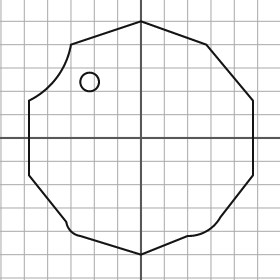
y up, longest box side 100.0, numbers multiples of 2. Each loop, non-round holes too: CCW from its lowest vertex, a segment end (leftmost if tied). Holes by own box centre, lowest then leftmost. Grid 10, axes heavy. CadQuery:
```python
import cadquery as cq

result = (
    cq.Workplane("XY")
    .moveTo(0.0, -50.0)
    .lineTo(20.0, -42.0)
    .threePointArc((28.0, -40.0), (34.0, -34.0))
    .lineTo(48.0, -16.0)
    .lineTo(48.0, 16.0)
    .lineTo(28.0, 40.0)
    .lineTo(0.0, 50.0)
    .lineTo(-30.0, 40.0)
    .threePointArc((-36.0, 26.0), (-48.0, 16.0))
    .lineTo(-48.0, -16.0)
    .lineTo(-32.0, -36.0)
    .threePointArc((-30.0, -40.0), (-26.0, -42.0))
    .close()
    .moveTo(-22.0, 24.0)
    .circle(4.0)
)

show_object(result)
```